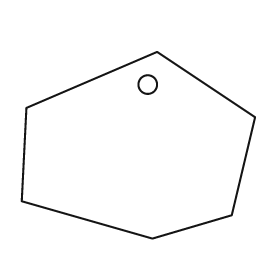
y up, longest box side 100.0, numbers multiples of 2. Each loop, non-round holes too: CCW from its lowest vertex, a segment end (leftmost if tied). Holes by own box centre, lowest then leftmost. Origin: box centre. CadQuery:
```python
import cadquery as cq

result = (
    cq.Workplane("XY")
    .moveTo(6.0, -40.0)
    .lineTo(40.0, -30.0)
    .lineTo(50.0, 12.0)
    .lineTo(8.0, 40.0)
    .lineTo(-48.0, 16.0)
    .lineTo(-50.0, -24.0)
    .close()
    .moveTo(4.0, 26.0)
    .circle(4.0)
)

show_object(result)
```